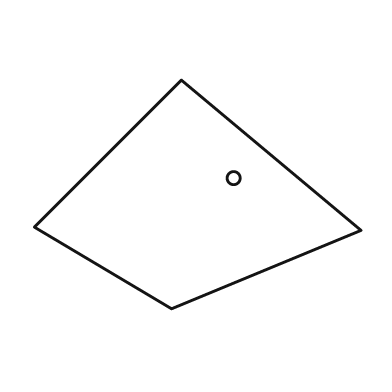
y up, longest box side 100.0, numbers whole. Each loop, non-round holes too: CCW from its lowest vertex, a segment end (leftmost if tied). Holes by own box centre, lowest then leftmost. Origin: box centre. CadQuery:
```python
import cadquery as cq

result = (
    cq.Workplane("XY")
    .moveTo(-8.0, -35.0)
    .lineTo(50.0, -11.0)
    .lineTo(-5.0, 35.0)
    .lineTo(-50.0, -10.0)
    .close()
    .moveTo(11.0, 5.0)
    .circle(2.0)
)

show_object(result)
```